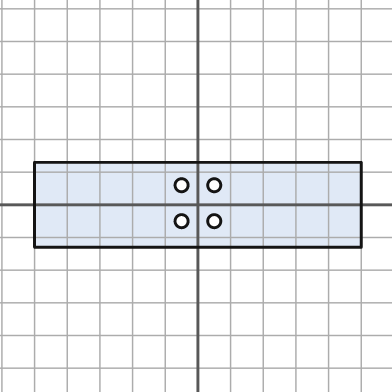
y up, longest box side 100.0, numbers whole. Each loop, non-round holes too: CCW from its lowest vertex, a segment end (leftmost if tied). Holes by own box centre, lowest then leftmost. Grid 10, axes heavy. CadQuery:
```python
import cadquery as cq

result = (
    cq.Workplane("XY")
    .moveTo(-50.0, -13.0)
    .lineTo(50.0, -13.0)
    .lineTo(50.0, 13.0)
    .lineTo(-50.0, 13.0)
    .close()
    .moveTo(-5.0, -5.0)
    .circle(2.0)
    .moveTo(5.0, -5.0)
    .circle(2.0)
    .moveTo(-5.0, 6.0)
    .circle(2.0)
    .moveTo(5.0, 6.0)
    .circle(2.0)
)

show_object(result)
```